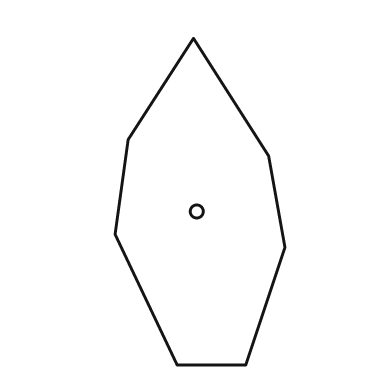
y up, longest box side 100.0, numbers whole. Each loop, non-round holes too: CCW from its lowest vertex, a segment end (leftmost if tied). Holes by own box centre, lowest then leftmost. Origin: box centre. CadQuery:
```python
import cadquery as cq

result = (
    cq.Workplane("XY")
    .moveTo(-7.0, -50.0)
    .lineTo(14.0, -50.0)
    .lineTo(26.0, -14.0)
    .lineTo(21.0, 14.0)
    .lineTo(-2.0, 50.0)
    .lineTo(-22.0, 19.0)
    .lineTo(-26.0, -10.0)
    .close()
    .moveTo(-1.0, -3.0)
    .circle(2.0)
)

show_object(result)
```